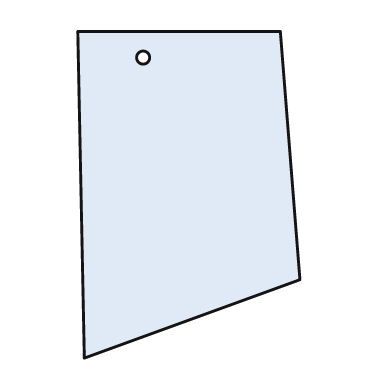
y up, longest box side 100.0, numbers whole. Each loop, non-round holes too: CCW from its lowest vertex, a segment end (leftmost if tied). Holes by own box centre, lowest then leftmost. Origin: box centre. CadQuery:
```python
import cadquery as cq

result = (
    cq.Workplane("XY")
    .moveTo(-32.0, -50.0)
    .lineTo(34.0, -26.0)
    .lineTo(28.0, 50.0)
    .lineTo(-34.0, 50.0)
    .close()
    .moveTo(-14.0, 42.0)
    .circle(2.0)
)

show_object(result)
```